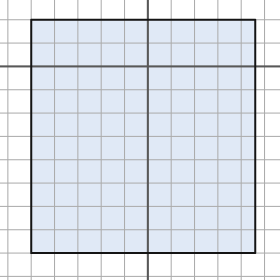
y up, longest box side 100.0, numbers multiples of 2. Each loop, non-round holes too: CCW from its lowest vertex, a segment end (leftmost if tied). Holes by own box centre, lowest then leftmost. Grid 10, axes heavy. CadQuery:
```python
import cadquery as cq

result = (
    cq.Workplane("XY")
    .moveTo(-50.0, -80.0)
    .lineTo(46.0, -80.0)
    .lineTo(46.0, 20.0)
    .lineTo(-50.0, 20.0)
    .close()
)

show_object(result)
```